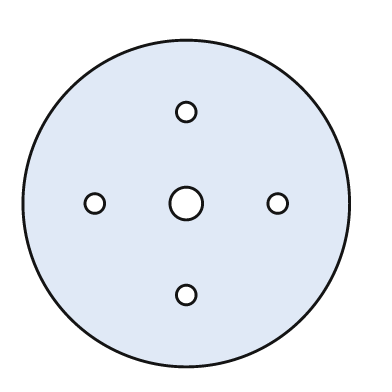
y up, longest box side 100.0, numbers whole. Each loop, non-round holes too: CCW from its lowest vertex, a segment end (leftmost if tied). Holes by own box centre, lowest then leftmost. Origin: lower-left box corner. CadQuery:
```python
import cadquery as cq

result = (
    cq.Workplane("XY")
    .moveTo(50.0, 50.0)
    .circle(50.0)
    .moveTo(50.0, 22.0)
    .circle(3.0)
    .moveTo(22.0, 50.0)
    .circle(3.0)
    .moveTo(50.0, 50.0)
    .circle(5.0)
    .moveTo(78.0, 50.0)
    .circle(3.0)
    .moveTo(50.0, 78.0)
    .circle(3.0)
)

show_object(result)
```